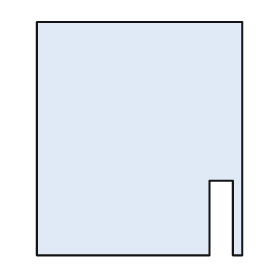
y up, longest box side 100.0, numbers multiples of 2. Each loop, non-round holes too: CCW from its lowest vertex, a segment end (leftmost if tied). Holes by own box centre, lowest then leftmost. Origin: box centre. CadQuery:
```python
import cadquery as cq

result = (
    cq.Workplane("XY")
    .moveTo(-44.0, -50.0)
    .lineTo(30.0, -50.0)
    .lineTo(30.0, -18.0)
    .lineTo(40.0, -18.0)
    .lineTo(40.0, -50.0)
    .lineTo(44.0, -50.0)
    .lineTo(44.0, 50.0)
    .lineTo(-44.0, 50.0)
    .close()
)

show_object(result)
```